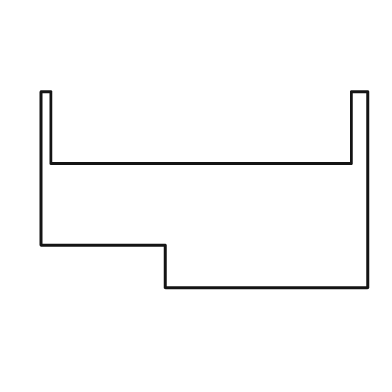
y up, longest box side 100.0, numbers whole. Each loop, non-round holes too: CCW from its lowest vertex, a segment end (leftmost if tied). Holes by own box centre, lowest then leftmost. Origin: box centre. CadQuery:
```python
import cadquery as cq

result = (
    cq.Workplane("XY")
    .moveTo(-12.0, -30.0)
    .lineTo(50.0, -30.0)
    .lineTo(50.0, 30.0)
    .lineTo(45.0, 30.0)
    .lineTo(45.0, 8.0)
    .lineTo(-47.0, 8.0)
    .lineTo(-47.0, 30.0)
    .lineTo(-50.0, 30.0)
    .lineTo(-50.0, -17.0)
    .lineTo(-12.0, -17.0)
    .close()
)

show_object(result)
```